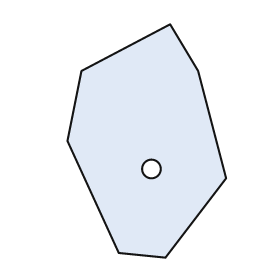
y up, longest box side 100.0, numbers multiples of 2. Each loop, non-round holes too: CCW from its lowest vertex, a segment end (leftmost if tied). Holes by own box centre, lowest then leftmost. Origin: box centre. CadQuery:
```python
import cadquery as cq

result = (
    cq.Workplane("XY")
    .moveTo(8.0, -50.0)
    .lineTo(34.0, -16.0)
    .lineTo(22.0, 30.0)
    .lineTo(10.0, 50.0)
    .lineTo(-28.0, 30.0)
    .lineTo(-34.0, 0.0)
    .lineTo(-12.0, -48.0)
    .close()
    .moveTo(2.0, -12.0)
    .circle(4.0)
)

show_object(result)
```